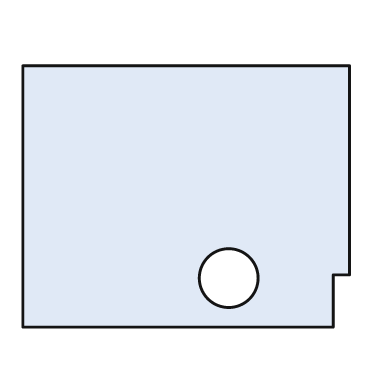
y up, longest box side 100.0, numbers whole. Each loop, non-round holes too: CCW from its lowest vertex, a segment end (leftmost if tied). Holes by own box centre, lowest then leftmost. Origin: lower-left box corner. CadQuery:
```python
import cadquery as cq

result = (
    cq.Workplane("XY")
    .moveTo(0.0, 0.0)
    .lineTo(95.0, 0.0)
    .lineTo(95.0, 16.0)
    .lineTo(100.0, 16.0)
    .lineTo(100.0, 80.0)
    .lineTo(0.0, 80.0)
    .close()
    .moveTo(63.0, 15.0)
    .circle(9.0)
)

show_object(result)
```